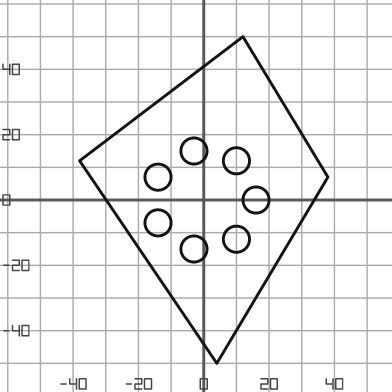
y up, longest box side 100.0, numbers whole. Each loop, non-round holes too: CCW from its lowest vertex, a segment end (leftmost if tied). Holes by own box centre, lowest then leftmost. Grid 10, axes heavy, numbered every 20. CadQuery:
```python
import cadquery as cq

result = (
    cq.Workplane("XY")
    .moveTo(4.0, -50.0)
    .lineTo(38.0, 7.0)
    .lineTo(12.0, 50.0)
    .lineTo(-38.0, 12.0)
    .close()
    .moveTo(-3.0, -15.0)
    .circle(4.0)
    .moveTo(10.0, -12.0)
    .circle(4.0)
    .moveTo(-14.0, -7.0)
    .circle(4.0)
    .moveTo(16.0, 0.0)
    .circle(4.0)
    .moveTo(-14.0, 7.0)
    .circle(4.0)
    .moveTo(10.0, 12.0)
    .circle(4.0)
    .moveTo(-3.0, 15.0)
    .circle(4.0)
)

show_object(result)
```